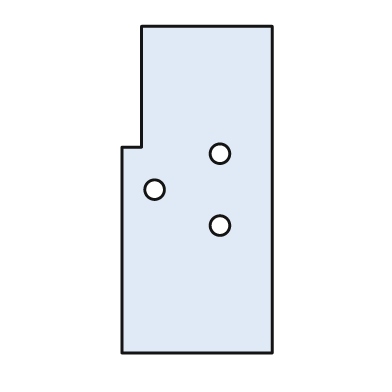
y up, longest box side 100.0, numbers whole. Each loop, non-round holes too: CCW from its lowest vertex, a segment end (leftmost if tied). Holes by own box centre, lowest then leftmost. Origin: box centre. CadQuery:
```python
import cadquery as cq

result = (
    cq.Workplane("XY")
    .moveTo(-23.0, -50.0)
    .lineTo(23.0, -50.0)
    .lineTo(23.0, 50.0)
    .lineTo(-17.0, 50.0)
    .lineTo(-17.0, 13.0)
    .lineTo(-23.0, 13.0)
    .close()
    .moveTo(7.0, -11.0)
    .circle(3.0)
    .moveTo(-13.0, 0.0)
    .circle(3.0)
    .moveTo(7.0, 11.0)
    .circle(3.0)
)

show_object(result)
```